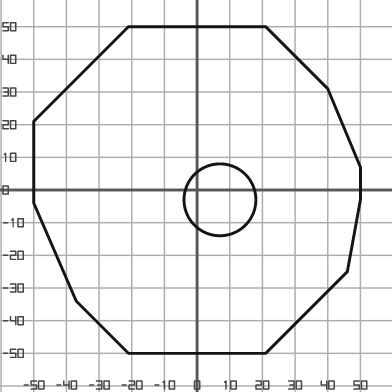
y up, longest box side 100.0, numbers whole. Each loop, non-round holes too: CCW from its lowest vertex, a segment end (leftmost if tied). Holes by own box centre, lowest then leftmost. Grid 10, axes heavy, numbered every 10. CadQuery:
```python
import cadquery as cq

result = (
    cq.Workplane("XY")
    .moveTo(-21.0, -50.0)
    .lineTo(21.0, -50.0)
    .lineTo(46.0, -25.0)
    .lineTo(50.0, -3.0)
    .lineTo(50.0, 7.0)
    .lineTo(40.0, 31.0)
    .lineTo(21.0, 50.0)
    .lineTo(-21.0, 50.0)
    .lineTo(-50.0, 21.0)
    .lineTo(-50.0, -4.0)
    .lineTo(-37.0, -34.0)
    .close()
    .moveTo(7.0, -3.0)
    .circle(11.0)
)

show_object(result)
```